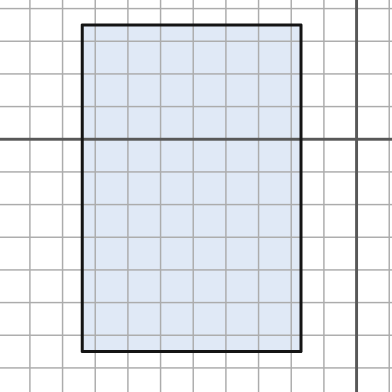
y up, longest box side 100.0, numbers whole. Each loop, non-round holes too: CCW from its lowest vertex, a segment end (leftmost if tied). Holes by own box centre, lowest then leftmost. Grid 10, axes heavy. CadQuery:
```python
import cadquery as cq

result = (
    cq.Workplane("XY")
    .moveTo(-84.0, -65.0)
    .lineTo(-17.0, -65.0)
    .lineTo(-17.0, 35.0)
    .lineTo(-84.0, 35.0)
    .close()
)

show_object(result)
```